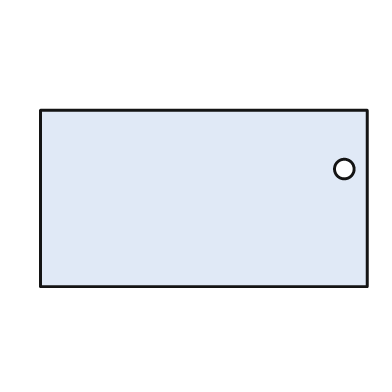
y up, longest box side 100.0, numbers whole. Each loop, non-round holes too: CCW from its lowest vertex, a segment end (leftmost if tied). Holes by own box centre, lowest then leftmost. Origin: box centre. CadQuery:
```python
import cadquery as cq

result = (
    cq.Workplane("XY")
    .moveTo(-50.0, -27.0)
    .lineTo(50.0, -27.0)
    .lineTo(50.0, 27.0)
    .lineTo(-50.0, 27.0)
    .close()
    .moveTo(43.0, 9.0)
    .circle(3.0)
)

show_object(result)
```